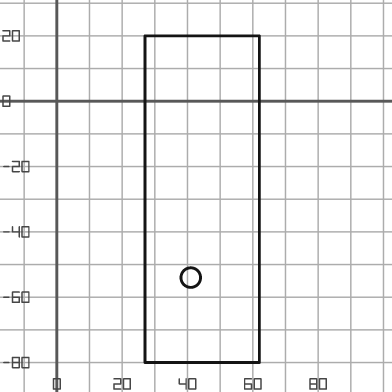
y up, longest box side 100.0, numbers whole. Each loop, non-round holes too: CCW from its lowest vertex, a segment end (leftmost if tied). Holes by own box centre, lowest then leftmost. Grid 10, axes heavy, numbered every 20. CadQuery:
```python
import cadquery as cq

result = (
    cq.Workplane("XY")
    .moveTo(27.0, -80.0)
    .lineTo(62.0, -80.0)
    .lineTo(62.0, 20.0)
    .lineTo(27.0, 20.0)
    .close()
    .moveTo(41.0, -54.0)
    .circle(3.0)
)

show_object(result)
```